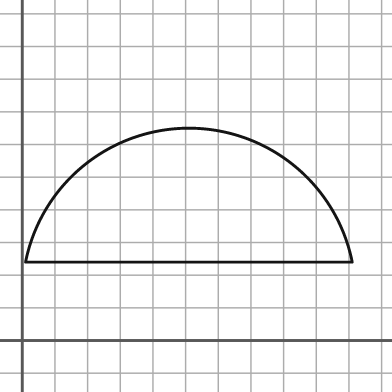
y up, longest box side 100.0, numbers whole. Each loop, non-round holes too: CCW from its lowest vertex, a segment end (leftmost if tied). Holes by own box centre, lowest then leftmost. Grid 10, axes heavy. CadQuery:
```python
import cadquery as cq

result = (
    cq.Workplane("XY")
    .moveTo(1.0, 24.0)
    .lineTo(101.0, 24.0)
    .threePointArc((51.0, 65.0), (1.0, 24.0))
    .close()
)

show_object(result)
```